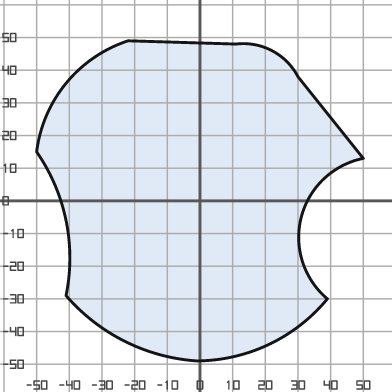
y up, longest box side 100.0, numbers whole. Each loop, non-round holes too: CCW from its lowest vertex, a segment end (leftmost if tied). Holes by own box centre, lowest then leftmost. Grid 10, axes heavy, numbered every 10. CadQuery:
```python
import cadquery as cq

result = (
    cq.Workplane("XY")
    .moveTo(-1.0, -49.0)
    .threePointArc((21.0, -44.0), (39.0, -30.0))
    .threePointArc((31.0, -5.0), (50.0, 13.0))
    .lineTo(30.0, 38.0)
    .threePointArc((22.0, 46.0), (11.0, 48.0))
    .lineTo(-22.0, 49.0)
    .threePointArc((-41.0, 36.0), (-50.0, 15.0))
    .threePointArc((-41.0, -6.0), (-41.0, -29.0))
    .threePointArc((-23.0, -43.0), (-1.0, -49.0))
    .close()
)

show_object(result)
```